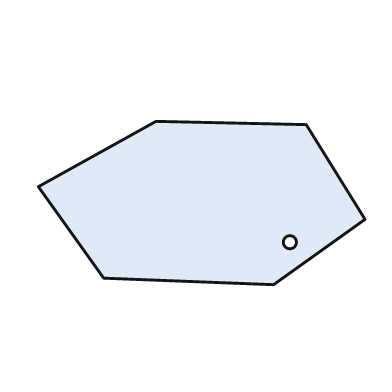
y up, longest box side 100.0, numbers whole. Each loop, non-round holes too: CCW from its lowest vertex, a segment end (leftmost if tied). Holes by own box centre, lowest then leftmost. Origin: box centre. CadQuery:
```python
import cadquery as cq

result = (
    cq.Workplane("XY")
    .moveTo(22.0, -25.0)
    .lineTo(50.0, -5.0)
    .lineTo(32.0, 24.0)
    .lineTo(-14.0, 25.0)
    .lineTo(-50.0, 5.0)
    .lineTo(-30.0, -23.0)
    .close()
    .moveTo(27.0, -12.0)
    .circle(2.0)
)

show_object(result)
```